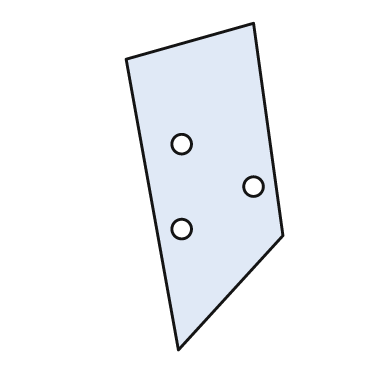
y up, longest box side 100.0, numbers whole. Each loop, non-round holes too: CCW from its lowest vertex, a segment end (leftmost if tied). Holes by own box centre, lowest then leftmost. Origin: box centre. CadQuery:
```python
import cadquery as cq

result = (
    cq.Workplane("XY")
    .moveTo(-8.0, -50.0)
    .lineTo(24.0, -15.0)
    .lineTo(15.0, 50.0)
    .lineTo(-24.0, 39.0)
    .close()
    .moveTo(-7.0, -13.0)
    .circle(3.0)
    .moveTo(15.0, 0.0)
    .circle(3.0)
    .moveTo(-7.0, 13.0)
    .circle(3.0)
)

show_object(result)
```